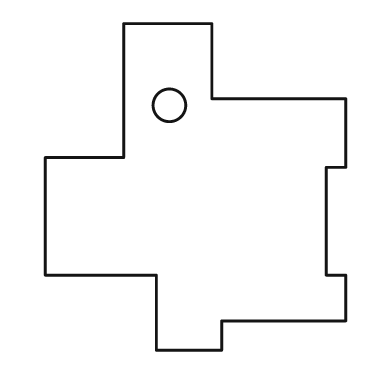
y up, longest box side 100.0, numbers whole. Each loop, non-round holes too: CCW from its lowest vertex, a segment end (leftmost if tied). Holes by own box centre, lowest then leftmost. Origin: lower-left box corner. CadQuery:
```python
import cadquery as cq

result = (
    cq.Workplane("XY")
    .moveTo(34.0, 0.0)
    .lineTo(54.0, 0.0)
    .lineTo(54.0, 9.0)
    .lineTo(92.0, 9.0)
    .lineTo(92.0, 23.0)
    .lineTo(86.0, 23.0)
    .lineTo(86.0, 56.0)
    .lineTo(92.0, 56.0)
    .lineTo(92.0, 77.0)
    .lineTo(51.0, 77.0)
    .lineTo(51.0, 100.0)
    .lineTo(24.0, 100.0)
    .lineTo(24.0, 59.0)
    .lineTo(0.0, 59.0)
    .lineTo(0.0, 23.0)
    .lineTo(34.0, 23.0)
    .close()
    .moveTo(38.0, 75.0)
    .circle(5.0)
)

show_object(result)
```